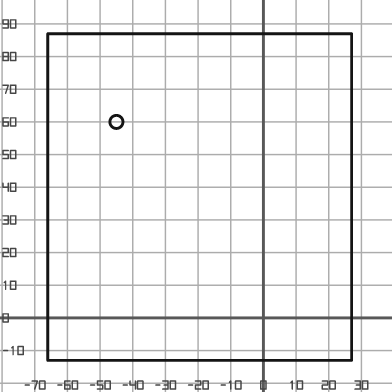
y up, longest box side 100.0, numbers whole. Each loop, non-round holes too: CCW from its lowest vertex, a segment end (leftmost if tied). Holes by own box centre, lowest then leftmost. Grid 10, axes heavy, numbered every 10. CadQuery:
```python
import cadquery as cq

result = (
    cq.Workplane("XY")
    .moveTo(-66.0, -13.0)
    .lineTo(27.0, -13.0)
    .lineTo(27.0, 87.0)
    .lineTo(-66.0, 87.0)
    .close()
    .moveTo(-45.0, 60.0)
    .circle(2.0)
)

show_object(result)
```